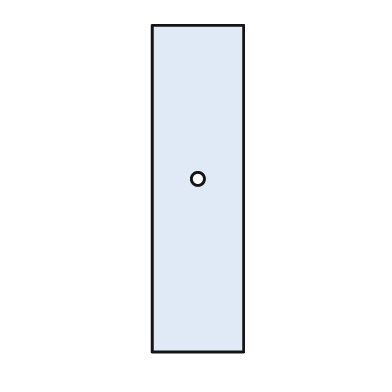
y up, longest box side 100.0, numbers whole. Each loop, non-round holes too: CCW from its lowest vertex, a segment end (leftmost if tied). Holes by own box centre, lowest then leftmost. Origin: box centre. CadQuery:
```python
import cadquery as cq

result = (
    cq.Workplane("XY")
    .moveTo(-14.0, -50.0)
    .lineTo(14.0, -50.0)
    .lineTo(14.0, 50.0)
    .lineTo(-14.0, 50.0)
    .close()
    .moveTo(0.0, 3.0)
    .circle(2.0)
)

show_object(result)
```